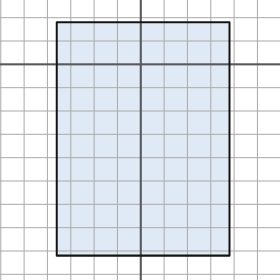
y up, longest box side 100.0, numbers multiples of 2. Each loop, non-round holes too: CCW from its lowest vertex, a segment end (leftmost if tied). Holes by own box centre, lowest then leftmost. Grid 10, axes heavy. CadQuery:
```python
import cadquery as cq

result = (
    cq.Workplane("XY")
    .moveTo(-36.0, -82.0)
    .lineTo(38.0, -82.0)
    .lineTo(38.0, 18.0)
    .lineTo(-36.0, 18.0)
    .close()
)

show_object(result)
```